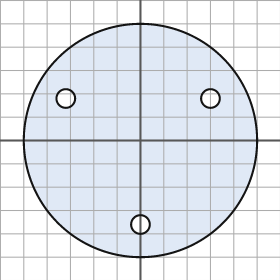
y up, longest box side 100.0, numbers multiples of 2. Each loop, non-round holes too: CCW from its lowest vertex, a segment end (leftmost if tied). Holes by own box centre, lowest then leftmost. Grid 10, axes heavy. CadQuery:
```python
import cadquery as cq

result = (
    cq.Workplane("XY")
    .moveTo(0.0, 0.0)
    .circle(50.0)
    .moveTo(0.0, -36.0)
    .circle(4.0)
    .moveTo(-32.0, 18.0)
    .circle(4.0)
    .moveTo(30.0, 18.0)
    .circle(4.0)
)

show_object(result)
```